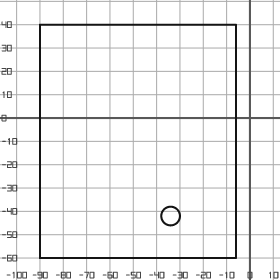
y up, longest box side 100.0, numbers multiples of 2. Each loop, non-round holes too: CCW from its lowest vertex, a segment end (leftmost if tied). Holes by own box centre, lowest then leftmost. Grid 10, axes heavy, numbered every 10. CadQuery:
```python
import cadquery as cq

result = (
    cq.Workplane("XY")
    .moveTo(-90.0, -60.0)
    .lineTo(-6.0, -60.0)
    .lineTo(-6.0, 40.0)
    .lineTo(-90.0, 40.0)
    .close()
    .moveTo(-34.0, -42.0)
    .circle(4.0)
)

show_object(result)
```